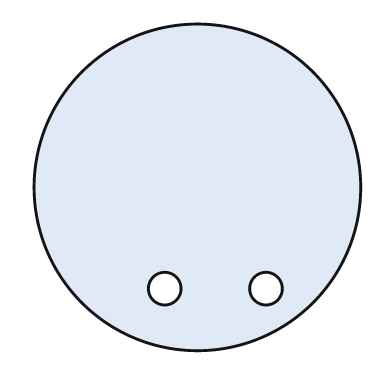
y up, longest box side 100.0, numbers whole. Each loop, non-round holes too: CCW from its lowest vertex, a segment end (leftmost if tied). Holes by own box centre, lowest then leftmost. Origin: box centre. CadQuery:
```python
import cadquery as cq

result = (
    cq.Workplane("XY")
    .moveTo(0.0, 0.0)
    .circle(50.0)
    .moveTo(-10.0, -31.0)
    .circle(5.0)
    .moveTo(21.0, -31.0)
    .circle(5.0)
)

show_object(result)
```